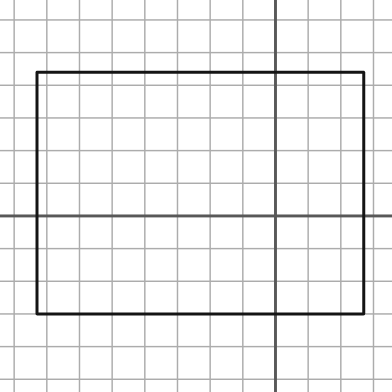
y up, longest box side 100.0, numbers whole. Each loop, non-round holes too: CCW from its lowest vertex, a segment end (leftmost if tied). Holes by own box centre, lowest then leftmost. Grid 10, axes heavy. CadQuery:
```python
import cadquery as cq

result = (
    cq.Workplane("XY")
    .moveTo(-73.0, -30.0)
    .lineTo(27.0, -30.0)
    .lineTo(27.0, 44.0)
    .lineTo(-73.0, 44.0)
    .close()
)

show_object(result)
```